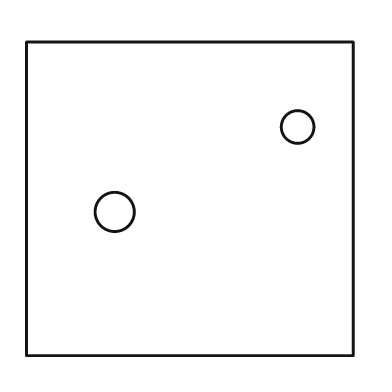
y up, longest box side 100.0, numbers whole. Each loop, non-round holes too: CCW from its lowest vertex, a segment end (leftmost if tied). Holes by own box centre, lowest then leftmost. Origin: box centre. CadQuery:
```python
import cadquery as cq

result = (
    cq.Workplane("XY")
    .moveTo(-50.0, -48.0)
    .lineTo(50.0, -48.0)
    .lineTo(50.0, 48.0)
    .lineTo(-50.0, 48.0)
    .close()
    .moveTo(-23.0, -4.0)
    .circle(6.0)
    .moveTo(33.0, 22.0)
    .circle(5.0)
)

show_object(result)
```